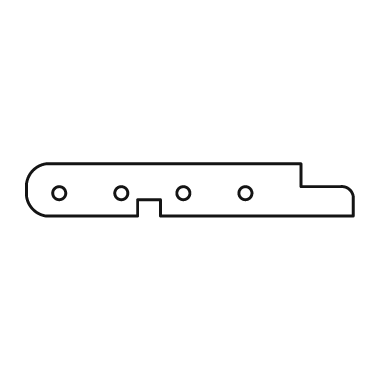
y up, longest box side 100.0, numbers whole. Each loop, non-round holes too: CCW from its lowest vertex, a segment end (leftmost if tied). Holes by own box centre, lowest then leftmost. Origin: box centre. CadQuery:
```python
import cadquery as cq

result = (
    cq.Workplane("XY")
    .moveTo(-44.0, -8.0)
    .lineTo(-16.0, -8.0)
    .lineTo(-16.0, -3.0)
    .lineTo(-9.0, -3.0)
    .lineTo(-9.0, -8.0)
    .lineTo(50.0, -8.0)
    .lineTo(50.0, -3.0)
    .threePointArc((49.0, 0.0), (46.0, 1.0))
    .lineTo(34.0, 1.0)
    .lineTo(34.0, 8.0)
    .lineTo(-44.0, 8.0)
    .threePointArc((-48.0, 6.0), (-50.0, 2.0))
    .lineTo(-50.0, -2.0)
    .threePointArc((-48.0, -6.0), (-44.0, -8.0))
    .close()
    .moveTo(-40.0, -1.0)
    .circle(2.0)
    .moveTo(-21.0, -1.0)
    .circle(2.0)
    .moveTo(-2.0, -1.0)
    .circle(2.0)
    .moveTo(17.0, -1.0)
    .circle(2.0)
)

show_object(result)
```